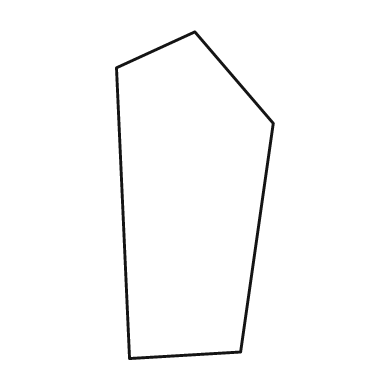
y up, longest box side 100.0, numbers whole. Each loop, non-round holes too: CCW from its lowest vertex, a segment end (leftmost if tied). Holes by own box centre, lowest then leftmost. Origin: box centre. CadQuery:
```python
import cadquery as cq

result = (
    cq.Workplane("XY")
    .moveTo(-20.0, -50.0)
    .lineTo(14.0, -48.0)
    .lineTo(24.0, 22.0)
    .lineTo(0.0, 50.0)
    .lineTo(-24.0, 39.0)
    .close()
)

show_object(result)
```